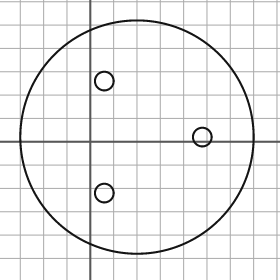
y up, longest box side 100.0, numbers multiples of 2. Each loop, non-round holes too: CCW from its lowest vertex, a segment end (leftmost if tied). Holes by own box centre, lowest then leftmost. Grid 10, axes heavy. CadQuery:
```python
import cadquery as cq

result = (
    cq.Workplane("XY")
    .moveTo(20.0, 2.0)
    .circle(50.0)
    .moveTo(6.0, -22.0)
    .circle(4.0)
    .moveTo(48.0, 2.0)
    .circle(4.0)
    .moveTo(6.0, 26.0)
    .circle(4.0)
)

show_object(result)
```